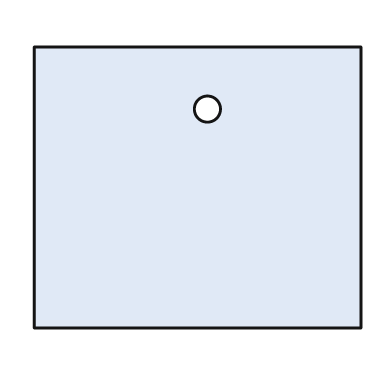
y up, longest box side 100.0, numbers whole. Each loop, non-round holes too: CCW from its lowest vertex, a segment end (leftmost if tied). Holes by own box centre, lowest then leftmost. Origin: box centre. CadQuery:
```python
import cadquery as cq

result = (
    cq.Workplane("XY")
    .moveTo(-50.0, -43.0)
    .lineTo(50.0, -43.0)
    .lineTo(50.0, 43.0)
    .lineTo(-50.0, 43.0)
    .close()
    .moveTo(3.0, 24.0)
    .circle(4.0)
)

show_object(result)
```